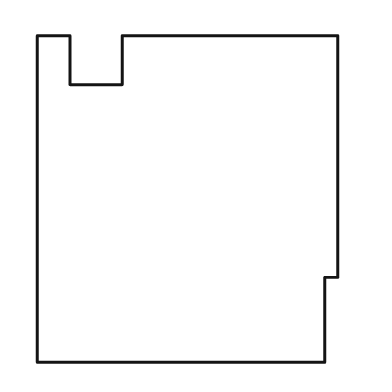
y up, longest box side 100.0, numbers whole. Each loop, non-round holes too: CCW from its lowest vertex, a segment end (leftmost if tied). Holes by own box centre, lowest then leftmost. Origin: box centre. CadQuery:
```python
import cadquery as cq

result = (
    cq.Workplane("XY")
    .moveTo(-46.0, -50.0)
    .lineTo(42.0, -50.0)
    .lineTo(42.0, -24.0)
    .lineTo(46.0, -24.0)
    .lineTo(46.0, 50.0)
    .lineTo(-20.0, 50.0)
    .lineTo(-20.0, 35.0)
    .lineTo(-36.0, 35.0)
    .lineTo(-36.0, 50.0)
    .lineTo(-46.0, 50.0)
    .close()
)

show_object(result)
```